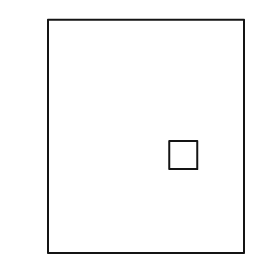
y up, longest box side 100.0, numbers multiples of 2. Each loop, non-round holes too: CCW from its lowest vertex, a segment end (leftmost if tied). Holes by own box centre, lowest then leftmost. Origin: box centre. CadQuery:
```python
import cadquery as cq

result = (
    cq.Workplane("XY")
    .moveTo(-42.0, -50.0)
    .lineTo(42.0, -50.0)
    .lineTo(42.0, 50.0)
    .lineTo(-42.0, 50.0)
    .close()
    .moveTo(10.0, -14.0)
    .lineTo(22.0, -14.0)
    .lineTo(22.0, -2.0)
    .lineTo(10.0, -2.0)
    .close()
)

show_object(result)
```